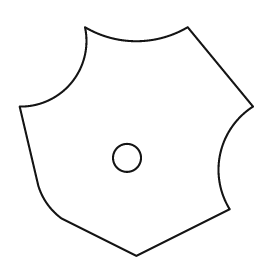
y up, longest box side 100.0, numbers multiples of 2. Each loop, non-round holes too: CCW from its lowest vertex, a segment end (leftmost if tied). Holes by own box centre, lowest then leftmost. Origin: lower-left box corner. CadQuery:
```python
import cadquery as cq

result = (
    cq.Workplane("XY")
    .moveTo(50.0, 0.0)
    .lineTo(90.0, 20.0)
    .threePointArc((86.0, 44.0), (100.0, 64.0))
    .lineTo(72.0, 98.0)
    .threePointArc((50.0, 92.0), (28.0, 98.0))
    .threePointArc((22.0, 74.0), (0.0, 64.0))
    .lineTo(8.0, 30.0)
    .threePointArc((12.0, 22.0), (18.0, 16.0))
    .close()
    .moveTo(46.0, 42.0)
    .circle(6.0)
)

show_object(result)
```